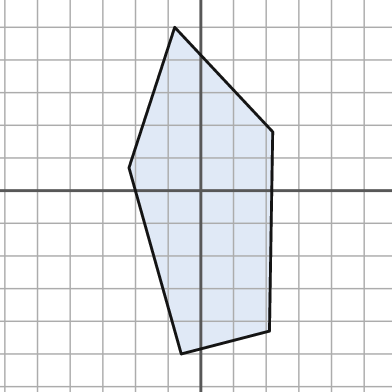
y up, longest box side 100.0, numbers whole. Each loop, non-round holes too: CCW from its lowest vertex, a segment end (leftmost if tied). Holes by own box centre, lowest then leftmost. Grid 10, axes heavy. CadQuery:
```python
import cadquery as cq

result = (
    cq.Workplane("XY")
    .moveTo(-6.0, -50.0)
    .lineTo(21.0, -43.0)
    .lineTo(22.0, 18.0)
    .lineTo(-8.0, 50.0)
    .lineTo(-22.0, 7.0)
    .close()
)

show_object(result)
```